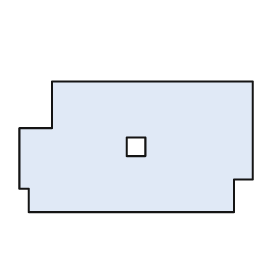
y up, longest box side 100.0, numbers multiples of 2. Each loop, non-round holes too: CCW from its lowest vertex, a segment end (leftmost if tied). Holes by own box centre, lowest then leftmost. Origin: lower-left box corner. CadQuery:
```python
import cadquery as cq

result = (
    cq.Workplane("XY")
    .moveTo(4.0, 0.0)
    .lineTo(92.0, 0.0)
    .lineTo(92.0, 14.0)
    .lineTo(100.0, 14.0)
    .lineTo(100.0, 56.0)
    .lineTo(14.0, 56.0)
    .lineTo(14.0, 36.0)
    .lineTo(0.0, 36.0)
    .lineTo(0.0, 10.0)
    .lineTo(4.0, 10.0)
    .close()
    .moveTo(46.0, 24.0)
    .lineTo(54.0, 24.0)
    .lineTo(54.0, 32.0)
    .lineTo(46.0, 32.0)
    .close()
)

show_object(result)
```